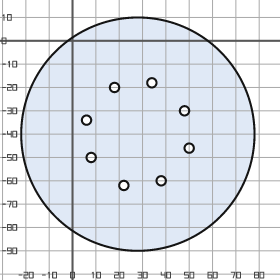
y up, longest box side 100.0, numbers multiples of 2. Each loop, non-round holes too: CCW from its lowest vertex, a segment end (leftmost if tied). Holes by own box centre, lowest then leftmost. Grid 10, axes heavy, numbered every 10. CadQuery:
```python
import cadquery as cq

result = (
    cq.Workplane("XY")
    .moveTo(28.0, -40.0)
    .circle(50.0)
    .moveTo(22.0, -62.0)
    .circle(2.0)
    .moveTo(38.0, -60.0)
    .circle(2.0)
    .moveTo(8.0, -50.0)
    .circle(2.0)
    .moveTo(50.0, -46.0)
    .circle(2.0)
    .moveTo(6.0, -34.0)
    .circle(2.0)
    .moveTo(48.0, -30.0)
    .circle(2.0)
    .moveTo(18.0, -20.0)
    .circle(2.0)
    .moveTo(34.0, -18.0)
    .circle(2.0)
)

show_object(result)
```